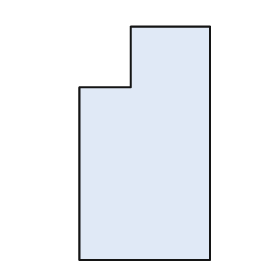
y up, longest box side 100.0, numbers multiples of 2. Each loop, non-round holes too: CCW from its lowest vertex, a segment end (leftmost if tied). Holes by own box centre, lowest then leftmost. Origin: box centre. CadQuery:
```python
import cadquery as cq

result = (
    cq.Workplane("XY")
    .moveTo(-28.0, -50.0)
    .lineTo(28.0, -50.0)
    .lineTo(28.0, 50.0)
    .lineTo(-6.0, 50.0)
    .lineTo(-6.0, 24.0)
    .lineTo(-28.0, 24.0)
    .close()
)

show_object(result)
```